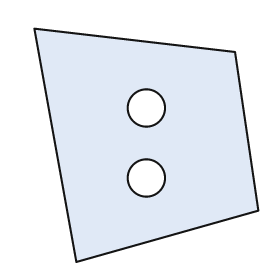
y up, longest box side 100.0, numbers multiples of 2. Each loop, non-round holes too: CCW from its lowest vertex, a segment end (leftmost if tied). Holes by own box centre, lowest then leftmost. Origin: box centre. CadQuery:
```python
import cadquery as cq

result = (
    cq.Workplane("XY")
    .moveTo(-30.0, -50.0)
    .lineTo(48.0, -28.0)
    .lineTo(38.0, 40.0)
    .lineTo(-48.0, 50.0)
    .close()
    .moveTo(0.0, -14.0)
    .circle(8.0)
    .moveTo(0.0, 16.0)
    .circle(8.0)
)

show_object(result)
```